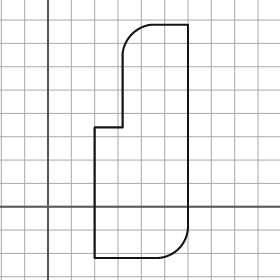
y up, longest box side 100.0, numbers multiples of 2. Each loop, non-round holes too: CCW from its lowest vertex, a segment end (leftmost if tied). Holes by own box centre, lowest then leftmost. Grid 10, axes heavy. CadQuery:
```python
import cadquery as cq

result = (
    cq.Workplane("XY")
    .moveTo(20.0, -22.0)
    .lineTo(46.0, -22.0)
    .threePointArc((56.0, -18.0), (60.0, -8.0))
    .lineTo(60.0, 78.0)
    .lineTo(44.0, 78.0)
    .threePointArc((36.0, 74.0), (32.0, 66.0))
    .lineTo(32.0, 34.0)
    .lineTo(20.0, 34.0)
    .close()
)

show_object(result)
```